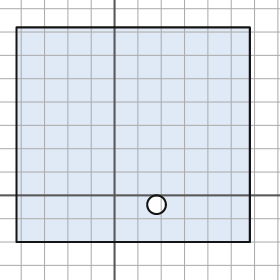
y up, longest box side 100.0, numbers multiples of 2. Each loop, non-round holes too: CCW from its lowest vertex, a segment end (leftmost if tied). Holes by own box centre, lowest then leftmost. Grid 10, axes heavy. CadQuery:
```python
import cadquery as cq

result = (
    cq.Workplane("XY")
    .moveTo(-42.0, -20.0)
    .lineTo(58.0, -20.0)
    .lineTo(58.0, 72.0)
    .lineTo(-42.0, 72.0)
    .close()
    .moveTo(18.0, -4.0)
    .circle(4.0)
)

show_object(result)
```